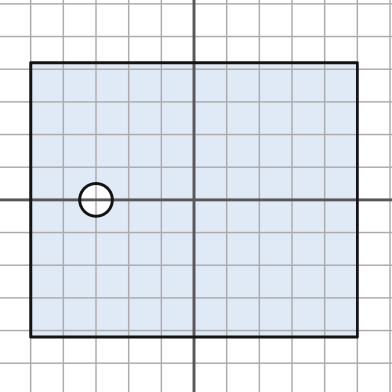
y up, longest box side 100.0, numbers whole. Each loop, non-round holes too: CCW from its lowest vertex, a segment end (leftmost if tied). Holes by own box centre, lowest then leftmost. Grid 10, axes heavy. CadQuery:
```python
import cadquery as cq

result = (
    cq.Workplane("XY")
    .moveTo(-50.0, -42.0)
    .lineTo(50.0, -42.0)
    .lineTo(50.0, 42.0)
    .lineTo(-50.0, 42.0)
    .close()
    .moveTo(-30.0, 0.0)
    .circle(5.0)
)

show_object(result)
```